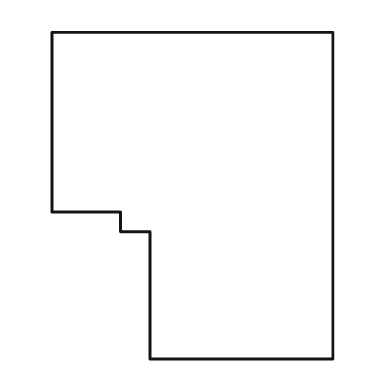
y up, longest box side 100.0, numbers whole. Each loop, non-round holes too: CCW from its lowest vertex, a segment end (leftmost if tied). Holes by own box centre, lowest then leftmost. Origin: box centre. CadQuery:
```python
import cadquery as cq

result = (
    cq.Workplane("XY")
    .moveTo(-13.0, -50.0)
    .lineTo(43.0, -50.0)
    .lineTo(43.0, 50.0)
    .lineTo(-43.0, 50.0)
    .lineTo(-43.0, -5.0)
    .lineTo(-22.0, -5.0)
    .lineTo(-22.0, -11.0)
    .lineTo(-13.0, -11.0)
    .close()
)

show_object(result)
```